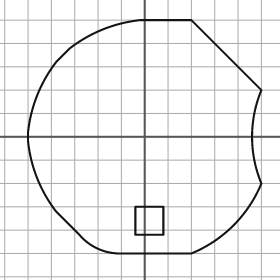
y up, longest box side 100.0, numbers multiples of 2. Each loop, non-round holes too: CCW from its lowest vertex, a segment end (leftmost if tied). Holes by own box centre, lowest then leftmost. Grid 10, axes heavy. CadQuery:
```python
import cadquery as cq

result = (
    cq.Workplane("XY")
    .moveTo(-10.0, -50.0)
    .lineTo(20.0, -50.0)
    .threePointArc((38.0, -38.0), (50.0, -20.0))
    .threePointArc((46.0, 0.0), (50.0, 20.0))
    .lineTo(20.0, 50.0)
    .lineTo(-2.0, 50.0)
    .threePointArc((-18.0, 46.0), (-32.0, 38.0))
    .lineTo(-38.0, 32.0)
    .threePointArc((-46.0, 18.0), (-50.0, 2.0))
    .lineTo(-50.0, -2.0)
    .threePointArc((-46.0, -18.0), (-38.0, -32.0))
    .lineTo(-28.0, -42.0)
    .threePointArc((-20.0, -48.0), (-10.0, -50.0))
    .close()
    .moveTo(-4.0, -42.0)
    .lineTo(8.0, -42.0)
    .lineTo(8.0, -30.0)
    .lineTo(-4.0, -30.0)
    .close()
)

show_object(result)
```